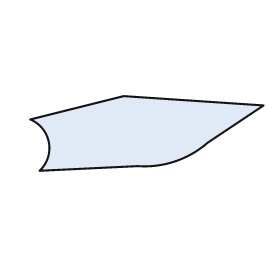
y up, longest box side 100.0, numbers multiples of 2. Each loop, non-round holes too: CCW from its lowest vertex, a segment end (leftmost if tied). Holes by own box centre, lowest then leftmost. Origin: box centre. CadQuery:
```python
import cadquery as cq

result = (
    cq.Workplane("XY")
    .moveTo(-46.0, -16.0)
    .lineTo(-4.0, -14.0)
    .threePointArc((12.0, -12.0), (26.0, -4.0))
    .lineTo(50.0, 12.0)
    .lineTo(-10.0, 16.0)
    .lineTo(-50.0, 6.0)
    .threePointArc((-42.0, -4.0), (-46.0, -16.0))
    .close()
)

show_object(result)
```